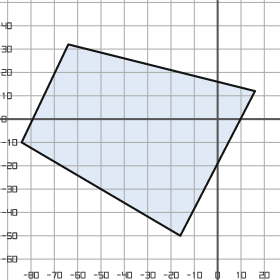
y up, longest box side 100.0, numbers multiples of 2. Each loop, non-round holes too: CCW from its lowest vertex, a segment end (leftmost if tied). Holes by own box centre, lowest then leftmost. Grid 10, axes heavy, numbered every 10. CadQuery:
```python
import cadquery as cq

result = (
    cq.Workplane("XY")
    .moveTo(-16.0, -50.0)
    .lineTo(16.0, 12.0)
    .lineTo(-64.0, 32.0)
    .lineTo(-84.0, -10.0)
    .close()
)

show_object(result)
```